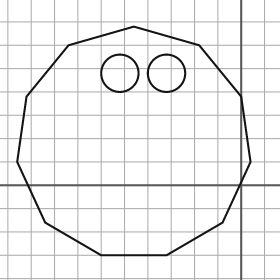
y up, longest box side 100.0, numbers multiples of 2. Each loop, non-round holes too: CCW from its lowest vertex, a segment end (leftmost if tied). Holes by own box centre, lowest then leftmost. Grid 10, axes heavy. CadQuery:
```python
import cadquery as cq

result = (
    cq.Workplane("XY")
    .moveTo(-60.0, -30.0)
    .lineTo(-32.0, -30.0)
    .lineTo(-8.0, -16.0)
    .lineTo(4.0, 10.0)
    .lineTo(0.0, 38.0)
    .lineTo(-18.0, 60.0)
    .lineTo(-46.0, 68.0)
    .lineTo(-74.0, 60.0)
    .lineTo(-92.0, 38.0)
    .lineTo(-96.0, 10.0)
    .lineTo(-84.0, -16.0)
    .close()
    .moveTo(-52.0, 48.0)
    .circle(8.0)
    .moveTo(-32.0, 48.0)
    .circle(8.0)
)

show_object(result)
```